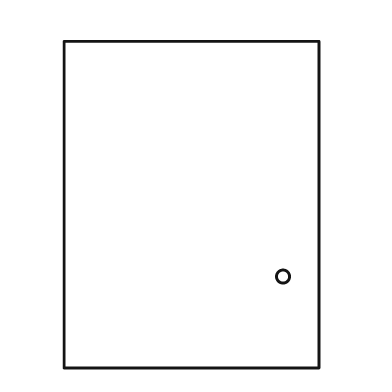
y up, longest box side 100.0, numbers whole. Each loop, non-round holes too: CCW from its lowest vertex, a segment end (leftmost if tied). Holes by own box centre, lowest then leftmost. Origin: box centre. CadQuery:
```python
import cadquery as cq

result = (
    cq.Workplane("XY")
    .moveTo(-39.0, -50.0)
    .lineTo(39.0, -50.0)
    .lineTo(39.0, 50.0)
    .lineTo(-39.0, 50.0)
    .close()
    .moveTo(28.0, -22.0)
    .circle(2.0)
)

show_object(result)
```